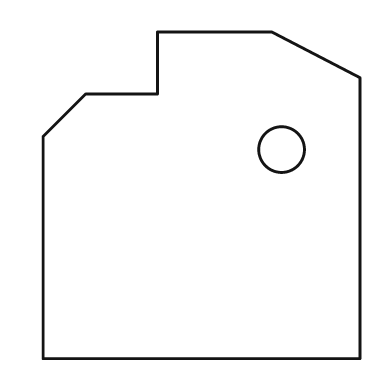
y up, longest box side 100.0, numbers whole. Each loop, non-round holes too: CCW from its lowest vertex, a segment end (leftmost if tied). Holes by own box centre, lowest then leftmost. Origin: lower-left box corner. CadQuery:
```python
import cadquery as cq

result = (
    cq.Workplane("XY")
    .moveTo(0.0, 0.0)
    .lineTo(97.0, 0.0)
    .lineTo(97.0, 86.0)
    .lineTo(70.0, 100.0)
    .lineTo(35.0, 100.0)
    .lineTo(35.0, 81.0)
    .lineTo(13.0, 81.0)
    .lineTo(0.0, 68.0)
    .close()
    .moveTo(73.0, 64.0)
    .circle(7.0)
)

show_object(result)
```